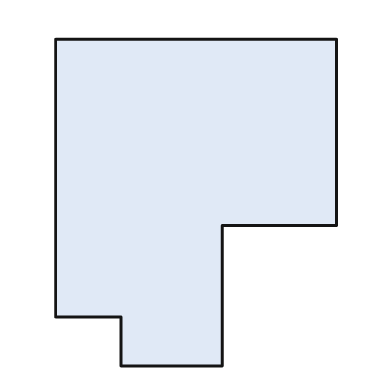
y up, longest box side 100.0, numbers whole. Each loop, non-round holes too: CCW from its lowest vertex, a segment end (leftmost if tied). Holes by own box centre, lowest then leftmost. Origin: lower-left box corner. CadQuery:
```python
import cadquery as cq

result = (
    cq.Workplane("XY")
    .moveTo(20.0, 0.0)
    .lineTo(51.0, 0.0)
    .lineTo(51.0, 43.0)
    .lineTo(86.0, 43.0)
    .lineTo(86.0, 100.0)
    .lineTo(0.0, 100.0)
    .lineTo(0.0, 15.0)
    .lineTo(20.0, 15.0)
    .close()
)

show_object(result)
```